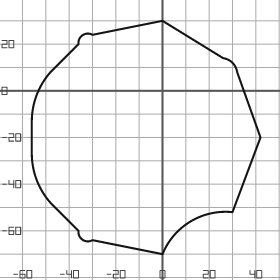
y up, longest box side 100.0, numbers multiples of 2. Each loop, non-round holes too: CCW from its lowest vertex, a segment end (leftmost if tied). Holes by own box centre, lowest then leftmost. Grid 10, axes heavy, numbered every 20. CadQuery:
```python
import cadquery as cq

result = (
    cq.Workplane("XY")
    .moveTo(0.0, -70.0)
    .threePointArc((12.0, -56.0), (30.0, -52.0))
    .lineTo(42.0, -20.0)
    .lineTo(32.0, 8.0)
    .threePointArc((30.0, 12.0), (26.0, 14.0))
    .lineTo(0.0, 30.0)
    .lineTo(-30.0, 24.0)
    .threePointArc((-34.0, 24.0), (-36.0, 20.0))
    .lineTo(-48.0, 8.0)
    .threePointArc((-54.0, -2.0), (-56.0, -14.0))
    .lineTo(-56.0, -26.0)
    .threePointArc((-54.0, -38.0), (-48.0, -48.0))
    .lineTo(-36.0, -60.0)
    .threePointArc((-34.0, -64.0), (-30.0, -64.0))
    .close()
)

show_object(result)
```